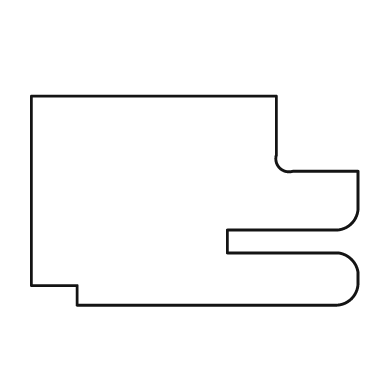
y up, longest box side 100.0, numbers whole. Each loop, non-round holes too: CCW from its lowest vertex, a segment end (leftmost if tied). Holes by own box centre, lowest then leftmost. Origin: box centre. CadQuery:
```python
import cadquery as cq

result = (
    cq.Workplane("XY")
    .moveTo(-36.0, -32.0)
    .lineTo(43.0, -32.0)
    .threePointArc((48.0, -30.0), (50.0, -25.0))
    .lineTo(50.0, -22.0)
    .threePointArc((48.0, -18.0), (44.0, -16.0))
    .lineTo(10.0, -16.0)
    .lineTo(10.0, -9.0)
    .lineTo(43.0, -9.0)
    .threePointArc((48.0, -7.0), (50.0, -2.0))
    .lineTo(50.0, 9.0)
    .lineTo(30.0, 9.0)
    .threePointArc((26.0, 10.0), (25.0, 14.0))
    .lineTo(25.0, 32.0)
    .lineTo(-50.0, 32.0)
    .lineTo(-50.0, -26.0)
    .lineTo(-36.0, -26.0)
    .close()
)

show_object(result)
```